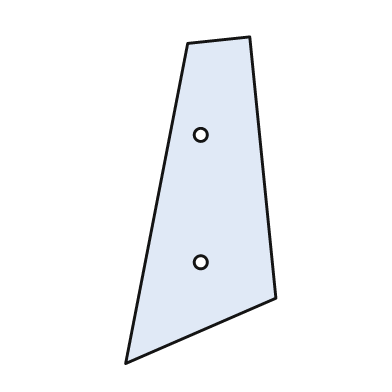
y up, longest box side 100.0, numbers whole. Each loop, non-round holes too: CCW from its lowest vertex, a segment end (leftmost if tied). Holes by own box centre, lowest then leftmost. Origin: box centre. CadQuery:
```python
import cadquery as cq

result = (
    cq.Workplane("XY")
    .moveTo(-23.0, -50.0)
    .lineTo(23.0, -30.0)
    .lineTo(15.0, 50.0)
    .lineTo(-4.0, 48.0)
    .close()
    .moveTo(0.0, -19.0)
    .circle(2.0)
    .moveTo(0.0, 20.0)
    .circle(2.0)
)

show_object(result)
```